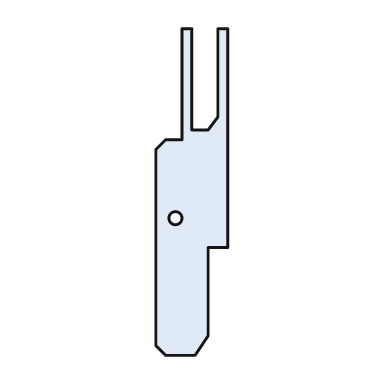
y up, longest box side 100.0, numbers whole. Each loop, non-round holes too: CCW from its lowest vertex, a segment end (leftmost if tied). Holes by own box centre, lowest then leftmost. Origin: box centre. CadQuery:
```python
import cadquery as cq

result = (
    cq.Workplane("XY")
    .moveTo(-8.0, -50.0)
    .lineTo(1.0, -50.0)
    .lineTo(5.0, -44.0)
    .lineTo(5.0, -17.0)
    .lineTo(11.0, -17.0)
    .lineTo(11.0, 50.0)
    .lineTo(8.0, 50.0)
    .lineTo(8.0, 23.0)
    .lineTo(5.0, 19.0)
    .lineTo(0.0, 19.0)
    .lineTo(0.0, 50.0)
    .lineTo(-3.0, 50.0)
    .lineTo(-3.0, 16.0)
    .lineTo(-8.0, 16.0)
    .lineTo(-11.0, 13.0)
    .lineTo(-11.0, -47.0)
    .close()
    .moveTo(-5.0, -8.0)
    .circle(2.0)
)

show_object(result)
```